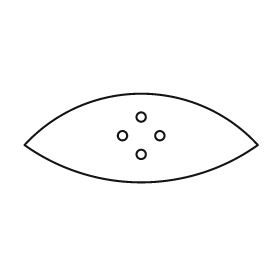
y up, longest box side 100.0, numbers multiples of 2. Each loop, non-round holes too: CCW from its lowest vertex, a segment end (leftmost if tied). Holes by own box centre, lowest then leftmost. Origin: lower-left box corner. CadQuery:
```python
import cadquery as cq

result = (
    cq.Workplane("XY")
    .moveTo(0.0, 16.0)
    .threePointArc((50.0, 0.0), (100.0, 16.0))
    .threePointArc((50.0, 38.0), (0.0, 16.0))
    .close()
    .moveTo(50.0, 12.0)
    .circle(2.0)
    .moveTo(42.0, 20.0)
    .circle(2.0)
    .moveTo(58.0, 20.0)
    .circle(2.0)
    .moveTo(50.0, 28.0)
    .circle(2.0)
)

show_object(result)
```